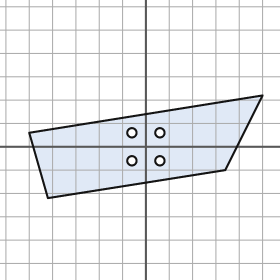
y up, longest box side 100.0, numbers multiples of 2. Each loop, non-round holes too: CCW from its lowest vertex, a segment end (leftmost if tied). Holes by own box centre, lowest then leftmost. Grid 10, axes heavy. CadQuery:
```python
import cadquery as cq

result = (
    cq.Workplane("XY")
    .moveTo(-42.0, -22.0)
    .lineTo(34.0, -10.0)
    .lineTo(50.0, 22.0)
    .lineTo(-50.0, 6.0)
    .close()
    .moveTo(-6.0, -6.0)
    .circle(2.0)
    .moveTo(6.0, -6.0)
    .circle(2.0)
    .moveTo(-6.0, 6.0)
    .circle(2.0)
    .moveTo(6.0, 6.0)
    .circle(2.0)
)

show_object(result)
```